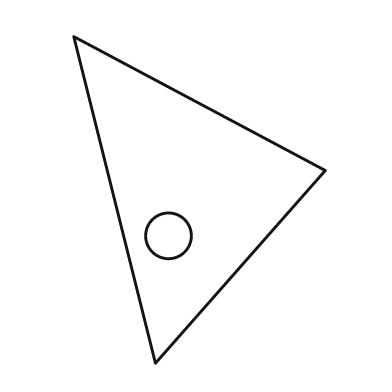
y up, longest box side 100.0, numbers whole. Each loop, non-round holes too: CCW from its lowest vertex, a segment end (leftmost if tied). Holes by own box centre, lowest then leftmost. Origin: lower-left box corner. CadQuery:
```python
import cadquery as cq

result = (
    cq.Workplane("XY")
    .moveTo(25.0, 0.0)
    .lineTo(77.0, 59.0)
    .lineTo(0.0, 100.0)
    .close()
    .moveTo(29.0, 39.0)
    .circle(7.0)
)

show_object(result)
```